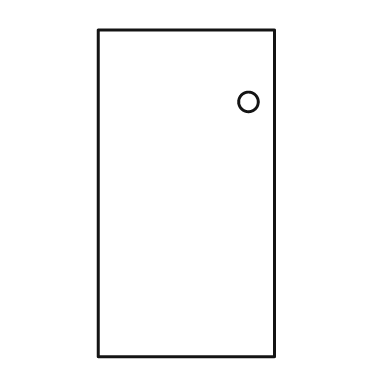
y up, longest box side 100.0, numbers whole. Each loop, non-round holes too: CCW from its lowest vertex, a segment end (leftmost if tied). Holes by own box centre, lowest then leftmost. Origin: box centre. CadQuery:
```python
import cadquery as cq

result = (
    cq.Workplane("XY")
    .moveTo(-27.0, -50.0)
    .lineTo(27.0, -50.0)
    .lineTo(27.0, 50.0)
    .lineTo(-27.0, 50.0)
    .close()
    .moveTo(19.0, 28.0)
    .circle(3.0)
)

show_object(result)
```